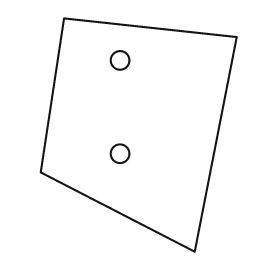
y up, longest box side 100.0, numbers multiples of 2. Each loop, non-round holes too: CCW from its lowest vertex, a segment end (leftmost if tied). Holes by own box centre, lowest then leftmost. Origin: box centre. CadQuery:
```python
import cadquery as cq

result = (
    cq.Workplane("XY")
    .moveTo(24.0, -50.0)
    .lineTo(42.0, 42.0)
    .lineTo(-32.0, 50.0)
    .lineTo(-42.0, -16.0)
    .close()
    .moveTo(-8.0, -8.0)
    .circle(4.0)
    .moveTo(-8.0, 32.0)
    .circle(4.0)
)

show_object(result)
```